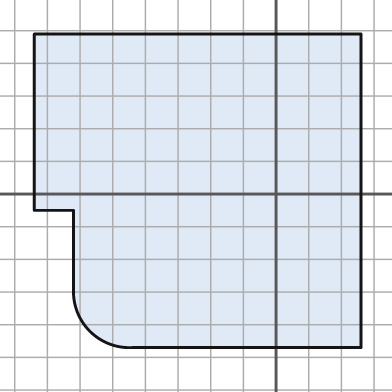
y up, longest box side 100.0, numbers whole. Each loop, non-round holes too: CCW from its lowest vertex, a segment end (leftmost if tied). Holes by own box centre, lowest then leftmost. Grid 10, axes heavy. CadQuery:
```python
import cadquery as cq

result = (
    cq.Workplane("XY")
    .moveTo(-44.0, -47.0)
    .lineTo(26.0, -47.0)
    .lineTo(26.0, 49.0)
    .lineTo(-74.0, 49.0)
    .lineTo(-74.0, -5.0)
    .lineTo(-62.0, -5.0)
    .lineTo(-62.0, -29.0)
    .threePointArc((-57.0, -42.0), (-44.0, -47.0))
    .close()
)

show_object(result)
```